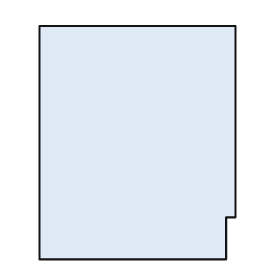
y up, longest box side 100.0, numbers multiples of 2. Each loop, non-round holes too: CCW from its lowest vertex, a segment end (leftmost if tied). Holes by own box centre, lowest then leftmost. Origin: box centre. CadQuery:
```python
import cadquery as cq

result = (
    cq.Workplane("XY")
    .moveTo(-42.0, -50.0)
    .lineTo(38.0, -50.0)
    .lineTo(38.0, -32.0)
    .lineTo(42.0, -32.0)
    .lineTo(42.0, 50.0)
    .lineTo(-42.0, 50.0)
    .close()
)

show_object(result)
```